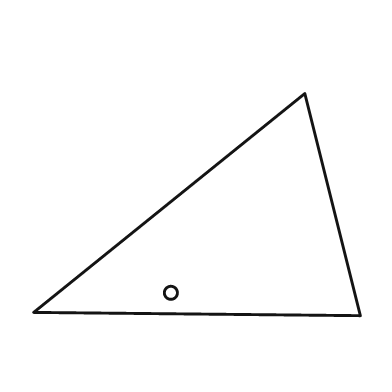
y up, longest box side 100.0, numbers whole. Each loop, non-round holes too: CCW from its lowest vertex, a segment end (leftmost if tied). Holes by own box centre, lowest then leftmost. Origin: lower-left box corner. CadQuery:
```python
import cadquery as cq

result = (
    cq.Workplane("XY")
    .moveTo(100.0, 0.0)
    .lineTo(83.0, 68.0)
    .lineTo(0.0, 1.0)
    .close()
    .moveTo(42.0, 7.0)
    .circle(2.0)
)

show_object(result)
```